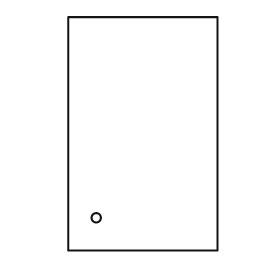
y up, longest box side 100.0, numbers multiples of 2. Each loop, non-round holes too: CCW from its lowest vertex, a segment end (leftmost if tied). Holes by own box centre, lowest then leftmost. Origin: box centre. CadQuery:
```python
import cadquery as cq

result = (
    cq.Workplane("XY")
    .moveTo(-32.0, -50.0)
    .lineTo(32.0, -50.0)
    .lineTo(32.0, 50.0)
    .lineTo(-32.0, 50.0)
    .close()
    .moveTo(-20.0, -36.0)
    .circle(2.0)
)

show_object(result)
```